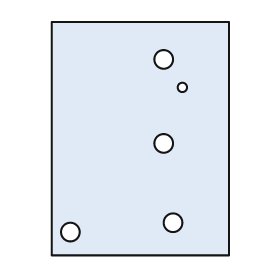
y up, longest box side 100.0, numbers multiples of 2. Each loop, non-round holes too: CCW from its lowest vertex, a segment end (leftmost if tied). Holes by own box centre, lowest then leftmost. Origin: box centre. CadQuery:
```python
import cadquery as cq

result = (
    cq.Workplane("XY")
    .moveTo(-38.0, -50.0)
    .lineTo(38.0, -50.0)
    .lineTo(38.0, 50.0)
    .lineTo(-38.0, 50.0)
    .close()
    .moveTo(-30.0, -40.0)
    .circle(4.0)
    .moveTo(14.0, -36.0)
    .circle(4.0)
    .moveTo(10.0, -2.0)
    .circle(4.0)
    .moveTo(18.0, 22.0)
    .circle(2.0)
    .moveTo(10.0, 34.0)
    .circle(4.0)
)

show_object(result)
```